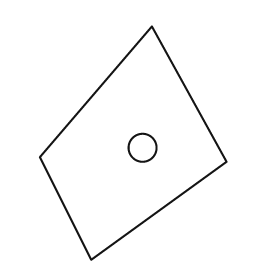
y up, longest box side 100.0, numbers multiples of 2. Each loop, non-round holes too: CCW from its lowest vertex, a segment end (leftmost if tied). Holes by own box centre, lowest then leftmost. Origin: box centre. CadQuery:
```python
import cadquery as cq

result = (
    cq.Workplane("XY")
    .moveTo(-18.0, -50.0)
    .lineTo(40.0, -8.0)
    .lineTo(8.0, 50.0)
    .lineTo(-40.0, -6.0)
    .close()
    .moveTo(4.0, -2.0)
    .circle(6.0)
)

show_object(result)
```